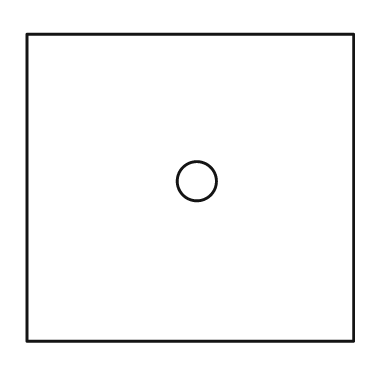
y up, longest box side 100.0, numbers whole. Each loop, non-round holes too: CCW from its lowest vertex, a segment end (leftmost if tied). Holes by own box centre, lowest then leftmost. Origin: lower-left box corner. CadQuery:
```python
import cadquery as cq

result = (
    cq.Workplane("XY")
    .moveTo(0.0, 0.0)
    .lineTo(100.0, 0.0)
    .lineTo(100.0, 94.0)
    .lineTo(0.0, 94.0)
    .close()
    .moveTo(52.0, 49.0)
    .circle(6.0)
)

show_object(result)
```